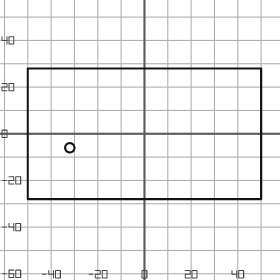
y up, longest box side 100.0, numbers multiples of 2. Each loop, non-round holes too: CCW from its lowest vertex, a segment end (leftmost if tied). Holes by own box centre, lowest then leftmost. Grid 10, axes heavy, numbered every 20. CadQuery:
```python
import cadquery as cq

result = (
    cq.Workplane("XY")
    .moveTo(-50.0, -28.0)
    .lineTo(50.0, -28.0)
    .lineTo(50.0, 28.0)
    .lineTo(-50.0, 28.0)
    .close()
    .moveTo(-32.0, -6.0)
    .circle(2.0)
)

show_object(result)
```